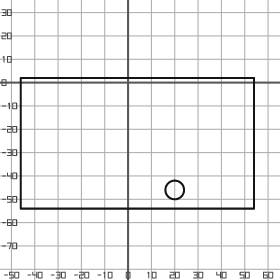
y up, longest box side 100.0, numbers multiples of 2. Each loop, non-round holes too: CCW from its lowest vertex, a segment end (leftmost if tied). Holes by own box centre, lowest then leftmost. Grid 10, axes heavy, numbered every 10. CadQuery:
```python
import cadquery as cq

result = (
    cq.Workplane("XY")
    .moveTo(-46.0, -54.0)
    .lineTo(54.0, -54.0)
    .lineTo(54.0, 2.0)
    .lineTo(-46.0, 2.0)
    .close()
    .moveTo(20.0, -46.0)
    .circle(4.0)
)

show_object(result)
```